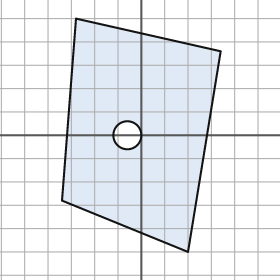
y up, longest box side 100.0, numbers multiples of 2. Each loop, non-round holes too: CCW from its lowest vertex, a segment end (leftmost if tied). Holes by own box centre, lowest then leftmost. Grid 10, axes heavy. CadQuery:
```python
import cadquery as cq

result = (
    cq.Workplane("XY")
    .moveTo(20.0, -50.0)
    .lineTo(34.0, 36.0)
    .lineTo(-28.0, 50.0)
    .lineTo(-34.0, -28.0)
    .close()
    .moveTo(-6.0, 0.0)
    .circle(6.0)
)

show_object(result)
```